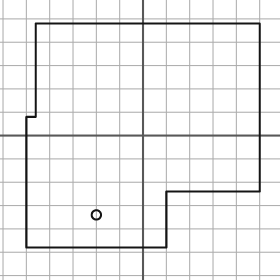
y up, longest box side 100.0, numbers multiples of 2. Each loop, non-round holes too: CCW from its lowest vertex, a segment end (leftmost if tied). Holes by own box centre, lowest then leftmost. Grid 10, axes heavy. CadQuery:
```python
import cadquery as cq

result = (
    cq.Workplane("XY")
    .moveTo(-50.0, -48.0)
    .lineTo(10.0, -48.0)
    .lineTo(10.0, -24.0)
    .lineTo(50.0, -24.0)
    .lineTo(50.0, 48.0)
    .lineTo(-46.0, 48.0)
    .lineTo(-46.0, 8.0)
    .lineTo(-50.0, 8.0)
    .close()
    .moveTo(-20.0, -34.0)
    .circle(2.0)
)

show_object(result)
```